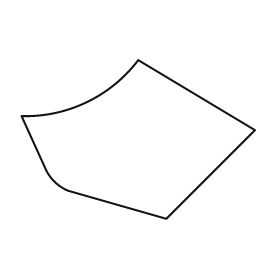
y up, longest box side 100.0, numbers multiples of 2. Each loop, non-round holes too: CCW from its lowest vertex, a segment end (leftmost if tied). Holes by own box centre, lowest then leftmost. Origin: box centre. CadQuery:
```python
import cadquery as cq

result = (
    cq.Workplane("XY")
    .moveTo(12.0, -34.0)
    .lineTo(50.0, 4.0)
    .lineTo(0.0, 34.0)
    .threePointArc((-22.0, 16.0), (-50.0, 10.0))
    .lineTo(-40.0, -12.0)
    .threePointArc((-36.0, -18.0), (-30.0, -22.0))
    .close()
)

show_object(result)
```